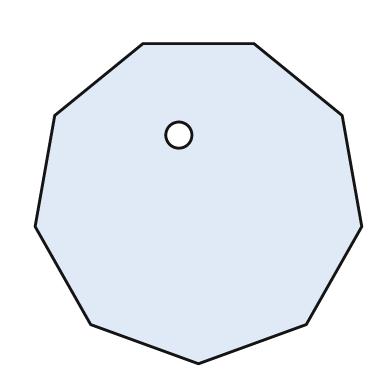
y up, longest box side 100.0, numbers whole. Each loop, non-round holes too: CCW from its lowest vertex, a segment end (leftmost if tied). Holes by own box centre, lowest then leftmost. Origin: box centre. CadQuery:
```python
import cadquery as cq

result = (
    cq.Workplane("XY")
    .moveTo(0.0, -49.0)
    .lineTo(33.0, -37.0)
    .lineTo(50.0, -7.0)
    .lineTo(44.0, 27.0)
    .lineTo(17.0, 49.0)
    .lineTo(-17.0, 49.0)
    .lineTo(-44.0, 27.0)
    .lineTo(-50.0, -7.0)
    .lineTo(-33.0, -37.0)
    .close()
    .moveTo(-6.0, 21.0)
    .circle(4.0)
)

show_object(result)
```